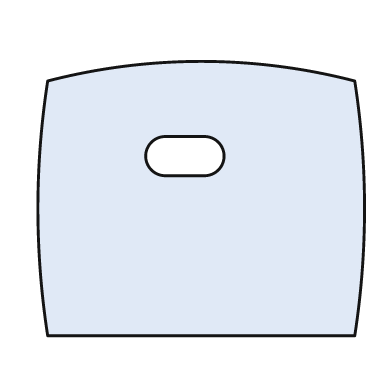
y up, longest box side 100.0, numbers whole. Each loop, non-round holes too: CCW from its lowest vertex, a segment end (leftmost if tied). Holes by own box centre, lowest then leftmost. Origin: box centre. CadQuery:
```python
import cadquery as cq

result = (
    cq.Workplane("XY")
    .moveTo(-47.0, -42.0)
    .lineTo(47.0, -42.0)
    .threePointArc((50.0, -3.0), (47.0, 36.0))
    .threePointArc((0.0, 42.0), (-47.0, 36.0))
    .threePointArc((-50.0, -3.0), (-47.0, -42.0))
    .close()
    .moveTo(-11.0, 7.0)
    .lineTo(1.0, 7.0)
    .threePointArc((7.0, 13.0), (1.0, 19.0))
    .lineTo(-11.0, 19.0)
    .threePointArc((-17.0, 13.0), (-11.0, 7.0))
    .close()
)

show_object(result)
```